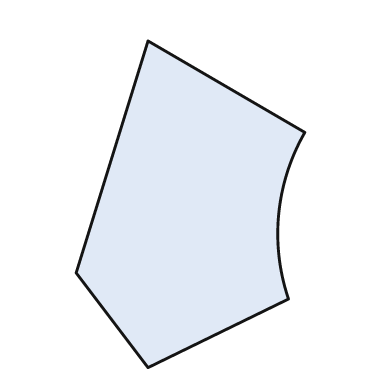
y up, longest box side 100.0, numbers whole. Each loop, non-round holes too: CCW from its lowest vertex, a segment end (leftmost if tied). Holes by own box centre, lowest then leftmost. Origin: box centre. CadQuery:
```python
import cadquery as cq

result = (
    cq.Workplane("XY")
    .moveTo(-13.0, -50.0)
    .lineTo(30.0, -29.0)
    .threePointArc((27.0, -3.0), (35.0, 22.0))
    .lineTo(-13.0, 50.0)
    .lineTo(-35.0, -21.0)
    .close()
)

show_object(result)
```